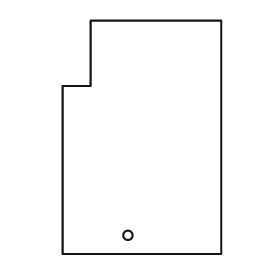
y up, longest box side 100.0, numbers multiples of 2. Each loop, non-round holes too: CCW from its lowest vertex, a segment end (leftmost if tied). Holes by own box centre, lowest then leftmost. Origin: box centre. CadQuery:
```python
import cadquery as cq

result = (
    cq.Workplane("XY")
    .moveTo(-34.0, -50.0)
    .lineTo(34.0, -50.0)
    .lineTo(34.0, 50.0)
    .lineTo(-22.0, 50.0)
    .lineTo(-22.0, 22.0)
    .lineTo(-34.0, 22.0)
    .close()
    .moveTo(-6.0, -42.0)
    .circle(2.0)
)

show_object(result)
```